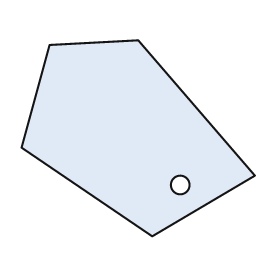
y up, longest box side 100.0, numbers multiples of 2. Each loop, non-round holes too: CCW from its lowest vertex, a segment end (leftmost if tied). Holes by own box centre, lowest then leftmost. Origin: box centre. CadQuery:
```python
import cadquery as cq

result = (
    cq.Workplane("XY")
    .moveTo(6.0, -42.0)
    .lineTo(50.0, -16.0)
    .lineTo(0.0, 42.0)
    .lineTo(-38.0, 40.0)
    .lineTo(-50.0, -4.0)
    .close()
    .moveTo(18.0, -20.0)
    .circle(4.0)
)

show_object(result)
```